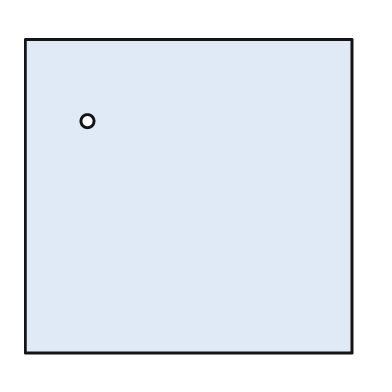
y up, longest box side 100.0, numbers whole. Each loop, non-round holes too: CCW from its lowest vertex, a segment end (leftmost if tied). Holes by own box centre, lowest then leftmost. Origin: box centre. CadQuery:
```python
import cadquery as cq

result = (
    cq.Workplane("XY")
    .moveTo(-50.0, -48.0)
    .lineTo(50.0, -48.0)
    .lineTo(50.0, 48.0)
    .lineTo(-50.0, 48.0)
    .close()
    .moveTo(-31.0, 23.0)
    .circle(2.0)
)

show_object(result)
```